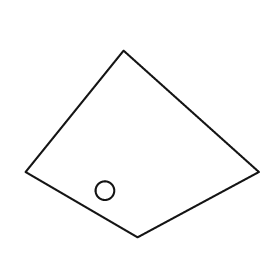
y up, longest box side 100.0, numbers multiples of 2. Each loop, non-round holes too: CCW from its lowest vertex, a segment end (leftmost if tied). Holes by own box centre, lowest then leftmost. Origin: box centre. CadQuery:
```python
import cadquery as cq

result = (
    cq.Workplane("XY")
    .moveTo(-2.0, -40.0)
    .lineTo(50.0, -12.0)
    .lineTo(-8.0, 40.0)
    .lineTo(-50.0, -12.0)
    .close()
    .moveTo(-16.0, -20.0)
    .circle(4.0)
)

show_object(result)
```